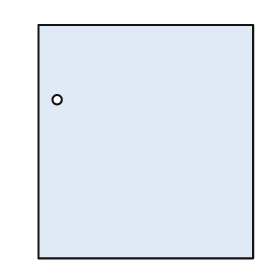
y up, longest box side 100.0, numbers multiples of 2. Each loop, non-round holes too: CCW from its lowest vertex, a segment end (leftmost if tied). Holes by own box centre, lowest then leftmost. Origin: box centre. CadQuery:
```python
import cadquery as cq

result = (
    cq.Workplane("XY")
    .moveTo(-46.0, -50.0)
    .lineTo(46.0, -50.0)
    .lineTo(46.0, 50.0)
    .lineTo(-46.0, 50.0)
    .close()
    .moveTo(-38.0, 18.0)
    .circle(2.0)
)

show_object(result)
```